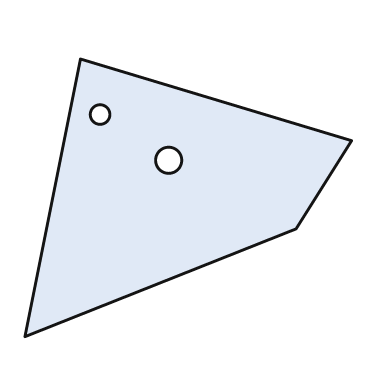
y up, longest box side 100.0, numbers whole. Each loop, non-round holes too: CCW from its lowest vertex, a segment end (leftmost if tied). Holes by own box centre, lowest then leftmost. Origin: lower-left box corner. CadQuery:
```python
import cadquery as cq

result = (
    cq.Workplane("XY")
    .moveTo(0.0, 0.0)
    .lineTo(83.0, 33.0)
    .lineTo(100.0, 60.0)
    .lineTo(17.0, 85.0)
    .close()
    .moveTo(44.0, 54.0)
    .circle(4.0)
    .moveTo(23.0, 68.0)
    .circle(3.0)
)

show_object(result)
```